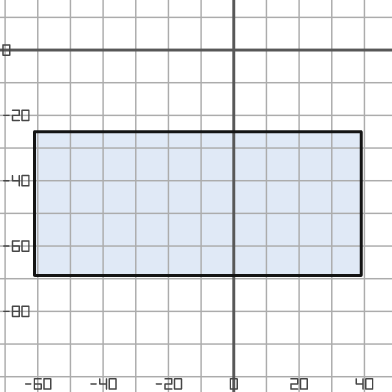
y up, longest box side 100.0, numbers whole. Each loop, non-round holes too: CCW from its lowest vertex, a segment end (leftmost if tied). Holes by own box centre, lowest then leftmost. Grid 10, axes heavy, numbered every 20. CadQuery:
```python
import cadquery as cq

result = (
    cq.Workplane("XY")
    .moveTo(-61.0, -69.0)
    .lineTo(39.0, -69.0)
    .lineTo(39.0, -25.0)
    .lineTo(-61.0, -25.0)
    .close()
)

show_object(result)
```